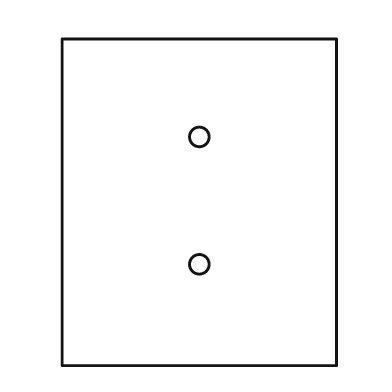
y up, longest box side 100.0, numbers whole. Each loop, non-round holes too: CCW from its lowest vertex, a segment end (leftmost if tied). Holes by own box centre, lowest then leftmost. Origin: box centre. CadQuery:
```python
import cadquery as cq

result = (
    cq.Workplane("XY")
    .moveTo(-42.0, -50.0)
    .lineTo(42.0, -50.0)
    .lineTo(42.0, 50.0)
    .lineTo(-42.0, 50.0)
    .close()
    .moveTo(0.0, -19.0)
    .circle(3.0)
    .moveTo(0.0, 20.0)
    .circle(3.0)
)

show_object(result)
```